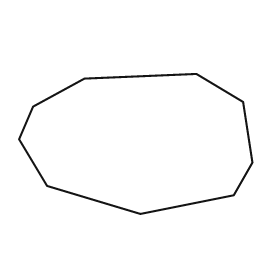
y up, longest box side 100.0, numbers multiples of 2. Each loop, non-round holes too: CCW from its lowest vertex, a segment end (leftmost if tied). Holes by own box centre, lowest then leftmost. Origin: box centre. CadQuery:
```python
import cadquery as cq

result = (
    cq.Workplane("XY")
    .moveTo(2.0, -30.0)
    .lineTo(42.0, -22.0)
    .lineTo(50.0, -8.0)
    .lineTo(46.0, 18.0)
    .lineTo(26.0, 30.0)
    .lineTo(-22.0, 28.0)
    .lineTo(-44.0, 16.0)
    .lineTo(-50.0, 2.0)
    .lineTo(-38.0, -18.0)
    .close()
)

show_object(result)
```